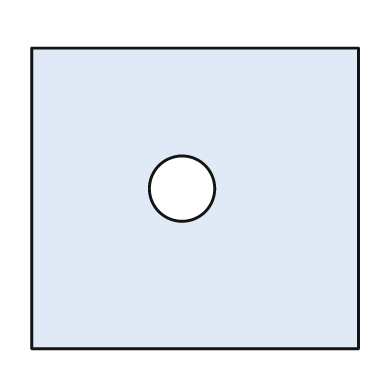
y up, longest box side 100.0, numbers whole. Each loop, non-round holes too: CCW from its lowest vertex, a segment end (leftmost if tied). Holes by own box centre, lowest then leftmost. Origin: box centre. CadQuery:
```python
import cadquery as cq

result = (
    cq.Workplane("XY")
    .moveTo(-50.0, -46.0)
    .lineTo(50.0, -46.0)
    .lineTo(50.0, 46.0)
    .lineTo(-50.0, 46.0)
    .close()
    .moveTo(-4.0, 3.0)
    .circle(10.0)
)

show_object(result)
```